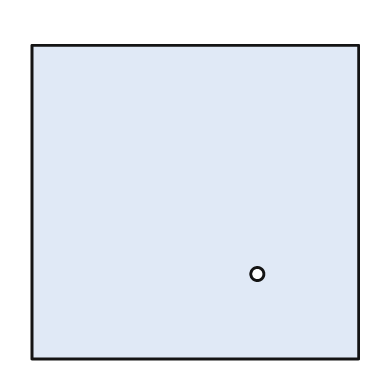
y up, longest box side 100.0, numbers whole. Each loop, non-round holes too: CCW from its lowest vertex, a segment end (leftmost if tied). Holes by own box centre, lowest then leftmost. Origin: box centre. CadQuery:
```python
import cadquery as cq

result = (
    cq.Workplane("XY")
    .moveTo(-50.0, -48.0)
    .lineTo(50.0, -48.0)
    .lineTo(50.0, 48.0)
    .lineTo(-50.0, 48.0)
    .close()
    .moveTo(19.0, -22.0)
    .circle(2.0)
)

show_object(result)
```